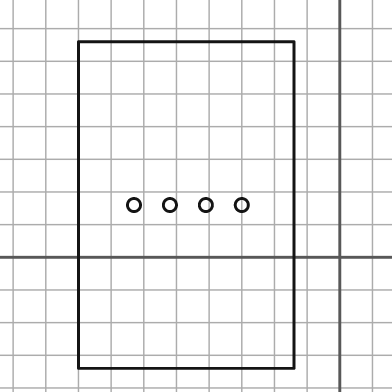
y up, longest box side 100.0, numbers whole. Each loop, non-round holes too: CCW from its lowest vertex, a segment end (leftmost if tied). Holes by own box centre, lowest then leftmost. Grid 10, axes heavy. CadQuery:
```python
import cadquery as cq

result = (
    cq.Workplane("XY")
    .moveTo(-80.0, -34.0)
    .lineTo(-14.0, -34.0)
    .lineTo(-14.0, 66.0)
    .lineTo(-80.0, 66.0)
    .close()
    .moveTo(-63.0, 16.0)
    .circle(2.0)
    .moveTo(-52.0, 16.0)
    .circle(2.0)
    .moveTo(-41.0, 16.0)
    .circle(2.0)
    .moveTo(-30.0, 16.0)
    .circle(2.0)
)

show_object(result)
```